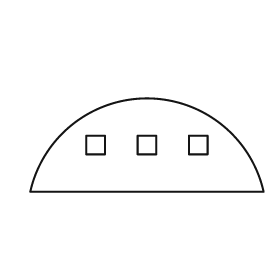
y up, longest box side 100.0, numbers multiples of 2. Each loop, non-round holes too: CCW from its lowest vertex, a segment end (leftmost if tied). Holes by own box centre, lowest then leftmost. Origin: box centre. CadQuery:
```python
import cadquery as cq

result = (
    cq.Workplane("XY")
    .moveTo(-50.0, -20.0)
    .lineTo(50.0, -20.0)
    .threePointArc((0.0, 20.0), (-50.0, -20.0))
    .close()
    .moveTo(-26.0, -4.0)
    .lineTo(-18.0, -4.0)
    .lineTo(-18.0, 4.0)
    .lineTo(-26.0, 4.0)
    .close()
    .moveTo(-4.0, -4.0)
    .lineTo(4.0, -4.0)
    .lineTo(4.0, 4.0)
    .lineTo(-4.0, 4.0)
    .close()
    .moveTo(18.0, -4.0)
    .lineTo(26.0, -4.0)
    .lineTo(26.0, 4.0)
    .lineTo(18.0, 4.0)
    .close()
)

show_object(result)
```